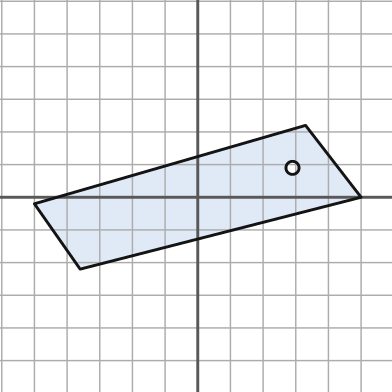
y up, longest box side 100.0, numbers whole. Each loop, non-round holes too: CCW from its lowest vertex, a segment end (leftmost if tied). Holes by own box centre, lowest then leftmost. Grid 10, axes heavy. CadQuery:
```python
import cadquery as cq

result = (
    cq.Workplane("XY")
    .moveTo(-36.0, -22.0)
    .lineTo(50.0, 0.0)
    .lineTo(33.0, 22.0)
    .lineTo(-50.0, -2.0)
    .close()
    .moveTo(29.0, 9.0)
    .circle(2.0)
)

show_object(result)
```